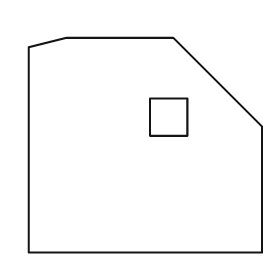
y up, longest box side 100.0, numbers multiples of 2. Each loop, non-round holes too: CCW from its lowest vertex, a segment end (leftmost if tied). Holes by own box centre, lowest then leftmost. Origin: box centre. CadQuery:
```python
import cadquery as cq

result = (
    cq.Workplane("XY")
    .moveTo(-50.0, -46.0)
    .lineTo(50.0, -46.0)
    .lineTo(50.0, 8.0)
    .lineTo(12.0, 46.0)
    .lineTo(-34.0, 46.0)
    .lineTo(-50.0, 42.0)
    .close()
    .moveTo(2.0, 4.0)
    .lineTo(18.0, 4.0)
    .lineTo(18.0, 20.0)
    .lineTo(2.0, 20.0)
    .close()
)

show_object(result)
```